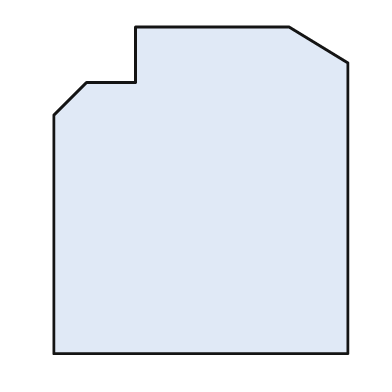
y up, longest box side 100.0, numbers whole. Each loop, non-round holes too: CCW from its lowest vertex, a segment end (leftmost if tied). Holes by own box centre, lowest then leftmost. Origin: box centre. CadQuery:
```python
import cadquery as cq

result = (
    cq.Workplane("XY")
    .moveTo(-45.0, -50.0)
    .lineTo(45.0, -50.0)
    .lineTo(45.0, 39.0)
    .lineTo(27.0, 50.0)
    .lineTo(-20.0, 50.0)
    .lineTo(-20.0, 33.0)
    .lineTo(-35.0, 33.0)
    .lineTo(-45.0, 23.0)
    .close()
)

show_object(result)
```